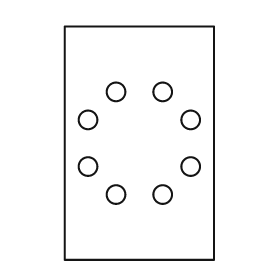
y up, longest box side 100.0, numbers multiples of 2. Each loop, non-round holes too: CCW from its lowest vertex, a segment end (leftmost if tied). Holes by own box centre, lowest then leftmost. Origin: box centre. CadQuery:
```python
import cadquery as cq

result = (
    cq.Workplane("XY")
    .moveTo(-32.0, -50.0)
    .lineTo(32.0, -50.0)
    .lineTo(32.0, 50.0)
    .lineTo(-32.0, 50.0)
    .close()
    .moveTo(-10.0, -22.0)
    .circle(4.0)
    .moveTo(10.0, -22.0)
    .circle(4.0)
    .moveTo(-22.0, -10.0)
    .circle(4.0)
    .moveTo(22.0, -10.0)
    .circle(4.0)
    .moveTo(-22.0, 10.0)
    .circle(4.0)
    .moveTo(22.0, 10.0)
    .circle(4.0)
    .moveTo(-10.0, 22.0)
    .circle(4.0)
    .moveTo(10.0, 22.0)
    .circle(4.0)
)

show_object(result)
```